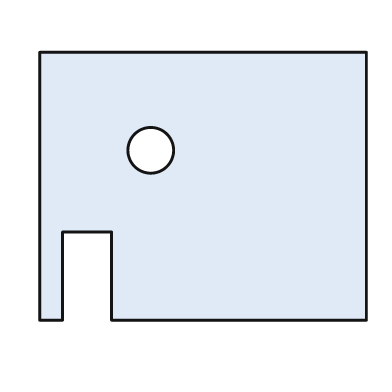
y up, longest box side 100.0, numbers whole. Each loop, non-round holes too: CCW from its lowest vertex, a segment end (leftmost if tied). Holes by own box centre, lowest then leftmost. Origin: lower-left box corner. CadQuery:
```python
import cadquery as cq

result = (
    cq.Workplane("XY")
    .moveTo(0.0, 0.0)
    .lineTo(7.0, 0.0)
    .lineTo(7.0, 27.0)
    .lineTo(22.0, 27.0)
    .lineTo(22.0, 0.0)
    .lineTo(100.0, 0.0)
    .lineTo(100.0, 82.0)
    .lineTo(0.0, 82.0)
    .close()
    .moveTo(34.0, 52.0)
    .circle(7.0)
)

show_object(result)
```